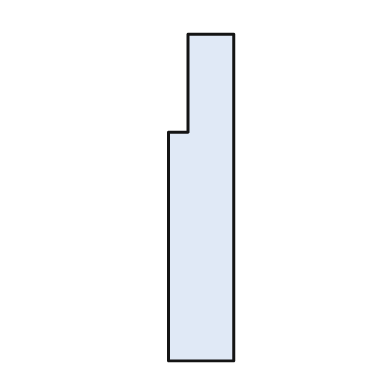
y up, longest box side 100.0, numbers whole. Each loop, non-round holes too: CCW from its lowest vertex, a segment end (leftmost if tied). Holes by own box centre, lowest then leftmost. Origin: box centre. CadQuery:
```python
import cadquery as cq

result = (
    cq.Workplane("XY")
    .moveTo(-10.0, -50.0)
    .lineTo(10.0, -50.0)
    .lineTo(10.0, 50.0)
    .lineTo(-4.0, 50.0)
    .lineTo(-4.0, 20.0)
    .lineTo(-10.0, 20.0)
    .close()
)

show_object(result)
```